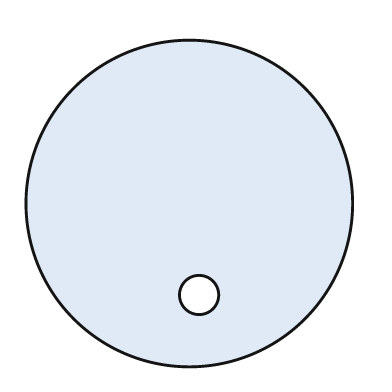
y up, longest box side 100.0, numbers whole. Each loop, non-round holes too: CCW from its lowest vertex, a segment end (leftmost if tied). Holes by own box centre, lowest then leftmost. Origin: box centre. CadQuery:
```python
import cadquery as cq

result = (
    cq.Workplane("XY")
    .moveTo(0.0, 0.0)
    .circle(50.0)
    .moveTo(3.0, -28.0)
    .circle(6.0)
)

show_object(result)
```